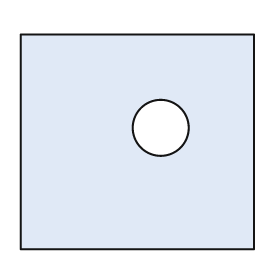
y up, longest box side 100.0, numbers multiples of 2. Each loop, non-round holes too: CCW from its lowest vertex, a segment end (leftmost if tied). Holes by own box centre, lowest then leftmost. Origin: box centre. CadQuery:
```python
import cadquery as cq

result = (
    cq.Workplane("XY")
    .moveTo(-50.0, -46.0)
    .lineTo(50.0, -46.0)
    .lineTo(50.0, 46.0)
    .lineTo(-50.0, 46.0)
    .close()
    .moveTo(10.0, 6.0)
    .circle(12.0)
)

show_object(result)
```